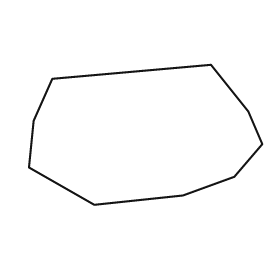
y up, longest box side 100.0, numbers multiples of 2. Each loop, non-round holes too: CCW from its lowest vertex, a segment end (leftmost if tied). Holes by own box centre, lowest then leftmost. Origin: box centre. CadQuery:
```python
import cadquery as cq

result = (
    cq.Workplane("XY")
    .moveTo(-22.0, -30.0)
    .lineTo(16.0, -26.0)
    .lineTo(38.0, -18.0)
    .lineTo(50.0, -4.0)
    .lineTo(44.0, 10.0)
    .lineTo(28.0, 30.0)
    .lineTo(-40.0, 24.0)
    .lineTo(-48.0, 6.0)
    .lineTo(-50.0, -14.0)
    .close()
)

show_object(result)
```